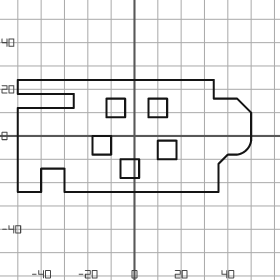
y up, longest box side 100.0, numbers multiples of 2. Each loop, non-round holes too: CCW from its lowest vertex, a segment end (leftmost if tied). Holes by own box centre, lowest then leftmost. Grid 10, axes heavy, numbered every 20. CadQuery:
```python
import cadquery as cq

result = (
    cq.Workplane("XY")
    .moveTo(-50.0, -24.0)
    .lineTo(-40.0, -24.0)
    .lineTo(-40.0, -14.0)
    .lineTo(-30.0, -14.0)
    .lineTo(-30.0, -24.0)
    .lineTo(36.0, -24.0)
    .lineTo(36.0, -12.0)
    .lineTo(40.0, -8.0)
    .lineTo(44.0, -8.0)
    .threePointArc((48.0, -6.0), (50.0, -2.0))
    .lineTo(50.0, 10.0)
    .lineTo(44.0, 16.0)
    .lineTo(34.0, 16.0)
    .lineTo(34.0, 24.0)
    .lineTo(-50.0, 24.0)
    .lineTo(-50.0, 18.0)
    .lineTo(-26.0, 18.0)
    .lineTo(-26.0, 12.0)
    .lineTo(-50.0, 12.0)
    .close()
    .moveTo(-6.0, -18.0)
    .lineTo(2.0, -18.0)
    .lineTo(2.0, -10.0)
    .lineTo(-6.0, -10.0)
    .close()
    .moveTo(10.0, -10.0)
    .lineTo(18.0, -10.0)
    .lineTo(18.0, -2.0)
    .lineTo(10.0, -2.0)
    .close()
    .moveTo(-18.0, -8.0)
    .lineTo(-10.0, -8.0)
    .lineTo(-10.0, 0.0)
    .lineTo(-18.0, 0.0)
    .close()
    .moveTo(-12.0, 8.0)
    .lineTo(-4.0, 8.0)
    .lineTo(-4.0, 16.0)
    .lineTo(-12.0, 16.0)
    .close()
    .moveTo(6.0, 8.0)
    .lineTo(14.0, 8.0)
    .lineTo(14.0, 16.0)
    .lineTo(6.0, 16.0)
    .close()
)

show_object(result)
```